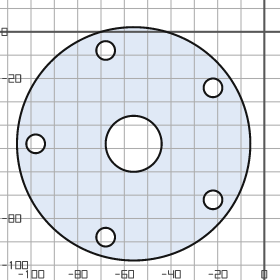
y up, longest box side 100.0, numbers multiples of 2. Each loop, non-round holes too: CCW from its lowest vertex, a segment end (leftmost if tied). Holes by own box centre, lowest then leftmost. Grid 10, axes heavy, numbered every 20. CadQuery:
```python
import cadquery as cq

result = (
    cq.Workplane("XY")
    .moveTo(-56.0, -48.0)
    .circle(50.0)
    .moveTo(-68.0, -88.0)
    .circle(4.0)
    .moveTo(-22.0, -72.0)
    .circle(4.0)
    .moveTo(-98.0, -48.0)
    .circle(4.0)
    .moveTo(-56.0, -48.0)
    .circle(12.0)
    .moveTo(-22.0, -24.0)
    .circle(4.0)
    .moveTo(-68.0, -8.0)
    .circle(4.0)
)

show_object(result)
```